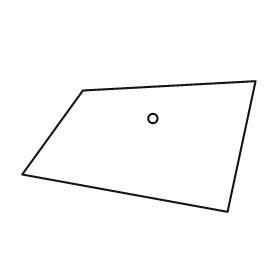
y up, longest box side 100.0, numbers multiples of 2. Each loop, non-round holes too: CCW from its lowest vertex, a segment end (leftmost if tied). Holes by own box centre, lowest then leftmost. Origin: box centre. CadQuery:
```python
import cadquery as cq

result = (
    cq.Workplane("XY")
    .moveTo(38.0, -28.0)
    .lineTo(50.0, 28.0)
    .lineTo(-24.0, 24.0)
    .lineTo(-50.0, -12.0)
    .close()
    .moveTo(6.0, 12.0)
    .circle(2.0)
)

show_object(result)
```